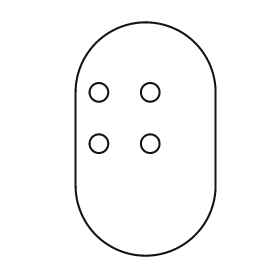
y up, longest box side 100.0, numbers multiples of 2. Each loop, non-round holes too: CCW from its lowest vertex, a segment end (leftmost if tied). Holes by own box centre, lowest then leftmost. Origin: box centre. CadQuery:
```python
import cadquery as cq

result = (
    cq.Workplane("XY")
    .moveTo(-30.0, -20.0)
    .threePointArc((0.0, -50.0), (30.0, -20.0))
    .lineTo(30.0, 20.0)
    .threePointArc((0.0, 50.0), (-30.0, 20.0))
    .close()
    .moveTo(-20.0, -2.0)
    .circle(4.0)
    .moveTo(2.0, -2.0)
    .circle(4.0)
    .moveTo(-20.0, 20.0)
    .circle(4.0)
    .moveTo(2.0, 20.0)
    .circle(4.0)
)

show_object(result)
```